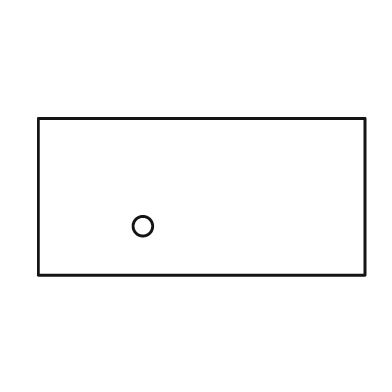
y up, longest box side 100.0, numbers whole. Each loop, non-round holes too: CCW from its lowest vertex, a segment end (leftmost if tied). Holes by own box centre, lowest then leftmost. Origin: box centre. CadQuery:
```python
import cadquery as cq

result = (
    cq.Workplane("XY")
    .moveTo(-50.0, -24.0)
    .lineTo(50.0, -24.0)
    .lineTo(50.0, 24.0)
    .lineTo(-50.0, 24.0)
    .close()
    .moveTo(-18.0, -9.0)
    .circle(3.0)
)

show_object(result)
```